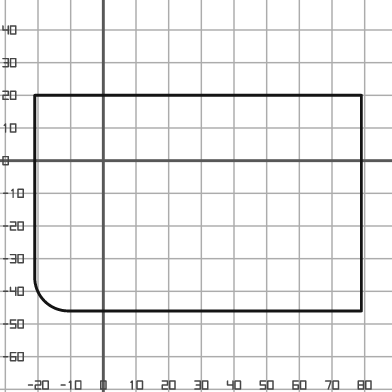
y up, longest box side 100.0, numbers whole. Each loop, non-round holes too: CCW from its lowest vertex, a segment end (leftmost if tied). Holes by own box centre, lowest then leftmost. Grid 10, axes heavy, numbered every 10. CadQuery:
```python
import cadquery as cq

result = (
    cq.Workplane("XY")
    .moveTo(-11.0, -46.0)
    .lineTo(79.0, -46.0)
    .lineTo(79.0, 20.0)
    .lineTo(-21.0, 20.0)
    .lineTo(-21.0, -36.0)
    .threePointArc((-18.0, -43.0), (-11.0, -46.0))
    .close()
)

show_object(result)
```